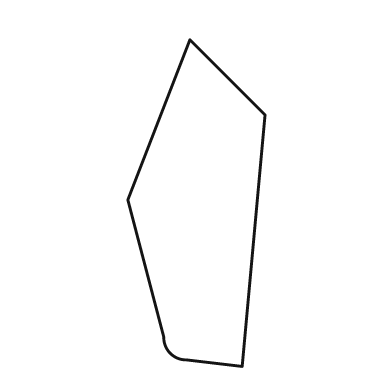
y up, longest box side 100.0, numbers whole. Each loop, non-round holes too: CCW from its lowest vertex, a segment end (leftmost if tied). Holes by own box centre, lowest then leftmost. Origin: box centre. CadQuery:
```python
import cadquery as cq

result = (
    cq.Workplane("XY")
    .moveTo(14.0, -50.0)
    .lineTo(21.0, 27.0)
    .lineTo(-2.0, 50.0)
    .lineTo(-21.0, 1.0)
    .lineTo(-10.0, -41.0)
    .threePointArc((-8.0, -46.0), (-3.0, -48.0))
    .close()
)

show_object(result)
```